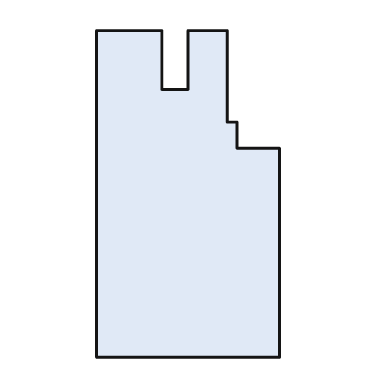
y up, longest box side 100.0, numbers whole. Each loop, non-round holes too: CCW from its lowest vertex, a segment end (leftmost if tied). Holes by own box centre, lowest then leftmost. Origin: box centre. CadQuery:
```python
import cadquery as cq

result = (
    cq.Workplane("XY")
    .moveTo(-28.0, -50.0)
    .lineTo(28.0, -50.0)
    .lineTo(28.0, 14.0)
    .lineTo(15.0, 14.0)
    .lineTo(15.0, 22.0)
    .lineTo(12.0, 22.0)
    .lineTo(12.0, 50.0)
    .lineTo(0.0, 50.0)
    .lineTo(0.0, 32.0)
    .lineTo(-8.0, 32.0)
    .lineTo(-8.0, 50.0)
    .lineTo(-28.0, 50.0)
    .close()
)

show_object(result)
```